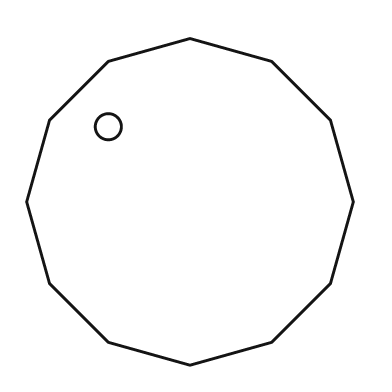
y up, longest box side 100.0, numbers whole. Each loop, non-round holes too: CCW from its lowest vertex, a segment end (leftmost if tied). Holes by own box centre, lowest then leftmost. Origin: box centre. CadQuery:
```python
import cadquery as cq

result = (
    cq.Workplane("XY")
    .moveTo(0.0, -50.0)
    .lineTo(25.0, -43.0)
    .lineTo(43.0, -25.0)
    .lineTo(50.0, 0.0)
    .lineTo(43.0, 25.0)
    .lineTo(25.0, 43.0)
    .lineTo(0.0, 50.0)
    .lineTo(-25.0, 43.0)
    .lineTo(-43.0, 25.0)
    .lineTo(-50.0, 0.0)
    .lineTo(-43.0, -25.0)
    .lineTo(-25.0, -43.0)
    .close()
    .moveTo(-25.0, 23.0)
    .circle(4.0)
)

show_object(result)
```